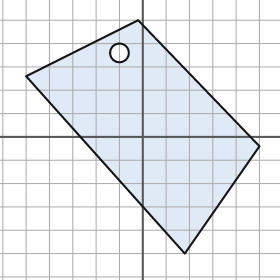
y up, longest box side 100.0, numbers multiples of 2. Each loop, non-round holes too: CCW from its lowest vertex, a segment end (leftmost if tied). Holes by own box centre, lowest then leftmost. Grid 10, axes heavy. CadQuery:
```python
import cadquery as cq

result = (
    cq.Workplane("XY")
    .moveTo(18.0, -50.0)
    .lineTo(50.0, -4.0)
    .lineTo(-2.0, 50.0)
    .lineTo(-50.0, 26.0)
    .close()
    .moveTo(-10.0, 36.0)
    .circle(4.0)
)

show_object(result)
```